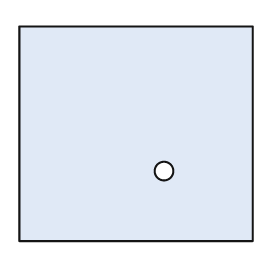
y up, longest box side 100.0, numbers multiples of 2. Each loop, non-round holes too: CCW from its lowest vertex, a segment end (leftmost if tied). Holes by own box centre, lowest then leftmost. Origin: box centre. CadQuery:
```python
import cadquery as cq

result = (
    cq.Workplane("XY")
    .moveTo(-50.0, -46.0)
    .lineTo(50.0, -46.0)
    .lineTo(50.0, 46.0)
    .lineTo(-50.0, 46.0)
    .close()
    .moveTo(12.0, -16.0)
    .circle(4.0)
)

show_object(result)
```